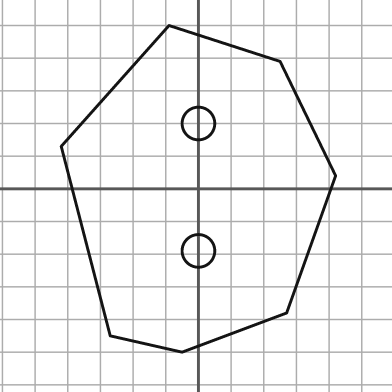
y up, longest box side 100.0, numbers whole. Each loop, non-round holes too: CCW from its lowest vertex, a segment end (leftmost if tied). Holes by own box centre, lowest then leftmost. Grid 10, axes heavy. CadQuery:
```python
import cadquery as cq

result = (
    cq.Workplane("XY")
    .moveTo(-5.0, -50.0)
    .lineTo(27.0, -38.0)
    .lineTo(42.0, 4.0)
    .lineTo(25.0, 39.0)
    .lineTo(-9.0, 50.0)
    .lineTo(-42.0, 13.0)
    .lineTo(-27.0, -45.0)
    .close()
    .moveTo(0.0, -19.0)
    .circle(5.0)
    .moveTo(0.0, 20.0)
    .circle(5.0)
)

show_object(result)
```